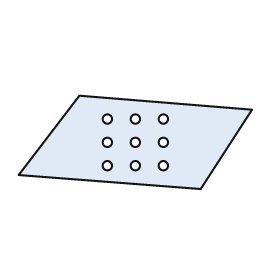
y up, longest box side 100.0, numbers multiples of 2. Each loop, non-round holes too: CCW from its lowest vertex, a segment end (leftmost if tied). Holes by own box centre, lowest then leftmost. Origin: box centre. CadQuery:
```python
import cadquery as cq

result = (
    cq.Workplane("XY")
    .moveTo(28.0, -20.0)
    .lineTo(50.0, 14.0)
    .lineTo(-24.0, 20.0)
    .lineTo(-50.0, -14.0)
    .close()
    .moveTo(-12.0, -10.0)
    .circle(2.0)
    .moveTo(0.0, -10.0)
    .circle(2.0)
    .moveTo(12.0, -10.0)
    .circle(2.0)
    .moveTo(-12.0, 0.0)
    .circle(2.0)
    .moveTo(0.0, 0.0)
    .circle(2.0)
    .moveTo(12.0, 0.0)
    .circle(2.0)
    .moveTo(-12.0, 10.0)
    .circle(2.0)
    .moveTo(0.0, 10.0)
    .circle(2.0)
    .moveTo(12.0, 10.0)
    .circle(2.0)
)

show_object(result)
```